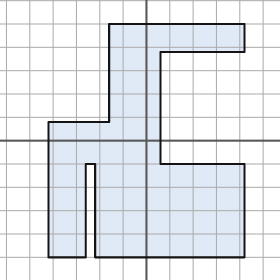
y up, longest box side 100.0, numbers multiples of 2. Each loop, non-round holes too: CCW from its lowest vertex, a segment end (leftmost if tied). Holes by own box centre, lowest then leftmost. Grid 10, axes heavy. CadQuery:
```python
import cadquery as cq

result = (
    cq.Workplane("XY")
    .moveTo(-42.0, -50.0)
    .lineTo(-26.0, -50.0)
    .lineTo(-26.0, -10.0)
    .lineTo(-22.0, -10.0)
    .lineTo(-22.0, -50.0)
    .lineTo(42.0, -50.0)
    .lineTo(42.0, -10.0)
    .lineTo(6.0, -10.0)
    .lineTo(6.0, 38.0)
    .lineTo(42.0, 38.0)
    .lineTo(42.0, 50.0)
    .lineTo(-16.0, 50.0)
    .lineTo(-16.0, 8.0)
    .lineTo(-42.0, 8.0)
    .close()
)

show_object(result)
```